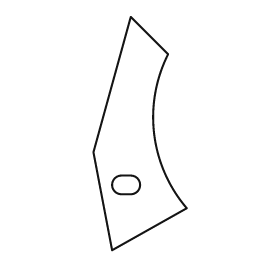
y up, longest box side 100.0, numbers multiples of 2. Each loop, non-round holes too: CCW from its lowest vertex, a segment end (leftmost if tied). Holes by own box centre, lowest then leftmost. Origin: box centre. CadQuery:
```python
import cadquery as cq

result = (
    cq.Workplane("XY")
    .moveTo(-12.0, -50.0)
    .lineTo(20.0, -32.0)
    .threePointArc((6.0, 0.0), (12.0, 34.0))
    .lineTo(-4.0, 50.0)
    .lineTo(-20.0, -8.0)
    .close()
    .moveTo(-8.0, -26.0)
    .lineTo(-4.0, -26.0)
    .threePointArc((0.0, -22.0), (-4.0, -18.0))
    .lineTo(-8.0, -18.0)
    .threePointArc((-12.0, -22.0), (-8.0, -26.0))
    .close()
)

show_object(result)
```